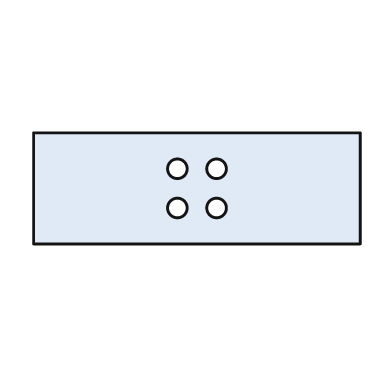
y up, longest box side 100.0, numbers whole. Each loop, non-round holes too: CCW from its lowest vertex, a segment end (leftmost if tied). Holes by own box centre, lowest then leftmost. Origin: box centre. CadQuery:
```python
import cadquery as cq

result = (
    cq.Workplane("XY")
    .moveTo(-50.0, -17.0)
    .lineTo(50.0, -17.0)
    .lineTo(50.0, 17.0)
    .lineTo(-50.0, 17.0)
    .close()
    .moveTo(-6.0, -6.0)
    .circle(3.0)
    .moveTo(6.0, -6.0)
    .circle(3.0)
    .moveTo(-6.0, 6.0)
    .circle(3.0)
    .moveTo(6.0, 6.0)
    .circle(3.0)
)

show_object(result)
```